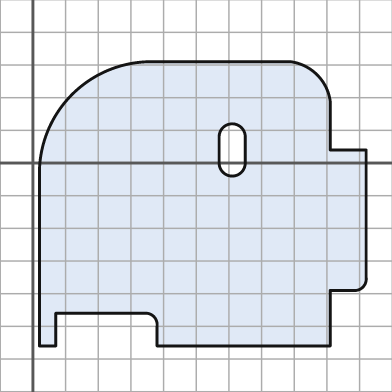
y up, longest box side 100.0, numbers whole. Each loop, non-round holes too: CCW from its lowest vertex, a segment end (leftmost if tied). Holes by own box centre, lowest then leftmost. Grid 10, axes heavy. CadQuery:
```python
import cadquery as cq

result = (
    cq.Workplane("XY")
    .moveTo(2.0, -56.0)
    .lineTo(7.0, -56.0)
    .lineTo(7.0, -46.0)
    .lineTo(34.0, -46.0)
    .threePointArc((37.0, -47.0), (38.0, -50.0))
    .lineTo(38.0, -56.0)
    .lineTo(91.0, -56.0)
    .lineTo(91.0, -39.0)
    .lineTo(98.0, -39.0)
    .threePointArc((101.0, -38.0), (102.0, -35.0))
    .lineTo(102.0, 4.0)
    .lineTo(91.0, 4.0)
    .lineTo(91.0, 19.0)
    .threePointArc((87.0, 27.0), (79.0, 31.0))
    .lineTo(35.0, 31.0)
    .threePointArc((12.0, 21.0), (2.0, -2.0))
    .close()
    .moveTo(57.0, 0.0)
    .threePointArc((61.0, -4.0), (65.0, 0.0))
    .lineTo(65.0, 8.0)
    .threePointArc((61.0, 12.0), (57.0, 8.0))
    .close()
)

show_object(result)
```